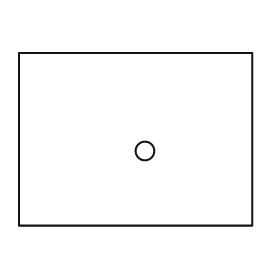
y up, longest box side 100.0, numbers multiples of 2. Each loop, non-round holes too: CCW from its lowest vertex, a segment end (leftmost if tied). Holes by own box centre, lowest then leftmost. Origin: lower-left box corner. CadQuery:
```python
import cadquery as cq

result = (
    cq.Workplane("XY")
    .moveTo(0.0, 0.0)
    .lineTo(100.0, 0.0)
    .lineTo(100.0, 74.0)
    .lineTo(0.0, 74.0)
    .close()
    .moveTo(54.0, 32.0)
    .circle(4.0)
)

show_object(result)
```